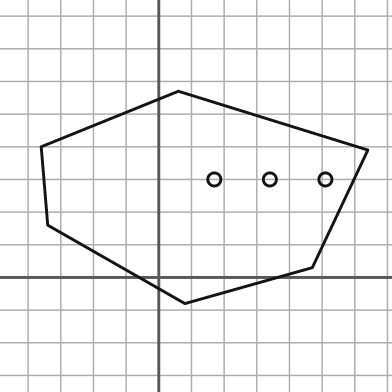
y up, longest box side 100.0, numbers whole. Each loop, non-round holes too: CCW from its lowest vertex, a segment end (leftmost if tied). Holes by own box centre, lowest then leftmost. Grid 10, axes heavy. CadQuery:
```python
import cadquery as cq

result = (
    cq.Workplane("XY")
    .moveTo(8.0, -8.0)
    .lineTo(47.0, 3.0)
    .lineTo(64.0, 39.0)
    .lineTo(6.0, 57.0)
    .lineTo(-36.0, 40.0)
    .lineTo(-34.0, 16.0)
    .close()
    .moveTo(17.0, 30.0)
    .circle(2.0)
    .moveTo(34.0, 30.0)
    .circle(2.0)
    .moveTo(51.0, 30.0)
    .circle(2.0)
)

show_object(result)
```